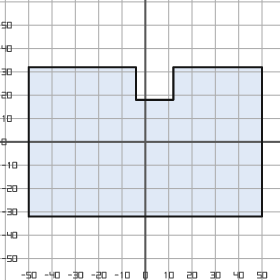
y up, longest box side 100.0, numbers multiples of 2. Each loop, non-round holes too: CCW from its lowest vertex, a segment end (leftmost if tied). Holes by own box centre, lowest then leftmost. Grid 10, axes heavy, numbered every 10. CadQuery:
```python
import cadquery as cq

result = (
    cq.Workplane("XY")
    .moveTo(-50.0, -32.0)
    .lineTo(50.0, -32.0)
    .lineTo(50.0, 32.0)
    .lineTo(12.0, 32.0)
    .lineTo(12.0, 18.0)
    .lineTo(-4.0, 18.0)
    .lineTo(-4.0, 32.0)
    .lineTo(-50.0, 32.0)
    .close()
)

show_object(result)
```